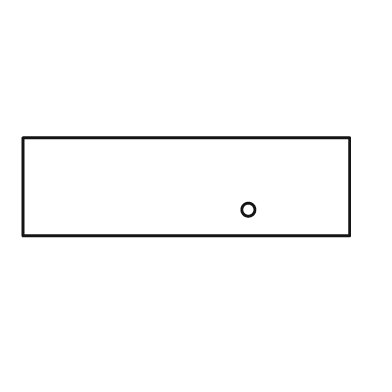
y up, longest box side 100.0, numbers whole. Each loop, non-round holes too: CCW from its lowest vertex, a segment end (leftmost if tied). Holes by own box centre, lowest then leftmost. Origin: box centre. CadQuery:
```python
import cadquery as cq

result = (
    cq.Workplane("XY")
    .moveTo(-50.0, -15.0)
    .lineTo(50.0, -15.0)
    .lineTo(50.0, 15.0)
    .lineTo(-50.0, 15.0)
    .close()
    .moveTo(19.0, -7.0)
    .circle(2.0)
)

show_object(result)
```